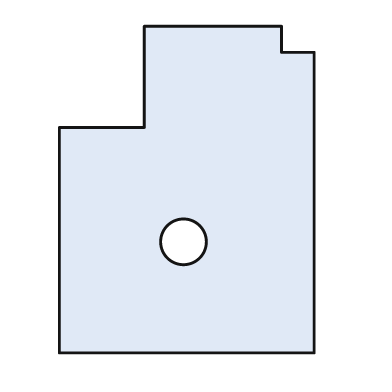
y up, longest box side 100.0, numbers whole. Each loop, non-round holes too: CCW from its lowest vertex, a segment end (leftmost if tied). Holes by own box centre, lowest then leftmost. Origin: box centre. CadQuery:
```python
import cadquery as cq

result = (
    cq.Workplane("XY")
    .moveTo(-39.0, -50.0)
    .lineTo(39.0, -50.0)
    .lineTo(39.0, 42.0)
    .lineTo(29.0, 42.0)
    .lineTo(29.0, 50.0)
    .lineTo(-13.0, 50.0)
    .lineTo(-13.0, 19.0)
    .lineTo(-39.0, 19.0)
    .close()
    .moveTo(-1.0, -16.0)
    .circle(7.0)
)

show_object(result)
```